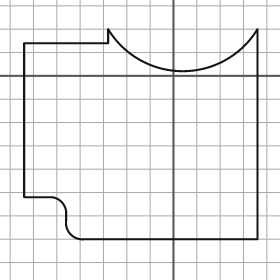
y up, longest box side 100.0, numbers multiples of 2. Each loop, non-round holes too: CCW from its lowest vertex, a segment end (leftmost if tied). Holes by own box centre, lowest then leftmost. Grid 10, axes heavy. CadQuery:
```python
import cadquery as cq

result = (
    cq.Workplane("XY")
    .moveTo(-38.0, -70.0)
    .lineTo(36.0, -70.0)
    .lineTo(36.0, 20.0)
    .threePointArc((4.0, 2.0), (-28.0, 20.0))
    .lineTo(-28.0, 14.0)
    .lineTo(-64.0, 14.0)
    .lineTo(-64.0, -52.0)
    .lineTo(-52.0, -52.0)
    .threePointArc((-48.0, -54.0), (-46.0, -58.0))
    .lineTo(-46.0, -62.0)
    .threePointArc((-44.0, -68.0), (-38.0, -70.0))
    .close()
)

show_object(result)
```